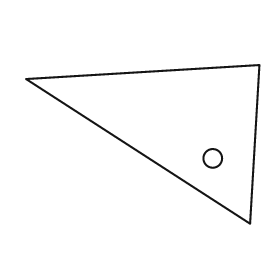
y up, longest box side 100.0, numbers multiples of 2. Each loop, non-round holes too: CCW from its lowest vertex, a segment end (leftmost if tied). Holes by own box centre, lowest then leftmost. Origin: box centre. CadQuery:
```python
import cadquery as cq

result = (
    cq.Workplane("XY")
    .moveTo(46.0, -34.0)
    .lineTo(50.0, 34.0)
    .lineTo(-50.0, 28.0)
    .close()
    .moveTo(30.0, -6.0)
    .circle(4.0)
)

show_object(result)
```